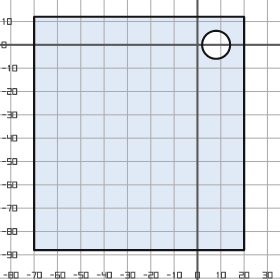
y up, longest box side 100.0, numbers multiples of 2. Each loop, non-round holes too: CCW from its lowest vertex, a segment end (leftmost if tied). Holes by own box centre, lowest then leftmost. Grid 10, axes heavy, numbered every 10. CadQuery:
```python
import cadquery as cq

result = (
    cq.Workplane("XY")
    .moveTo(-70.0, -88.0)
    .lineTo(20.0, -88.0)
    .lineTo(20.0, 12.0)
    .lineTo(-70.0, 12.0)
    .close()
    .moveTo(8.0, 0.0)
    .circle(6.0)
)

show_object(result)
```